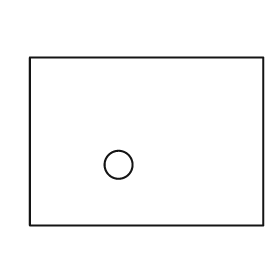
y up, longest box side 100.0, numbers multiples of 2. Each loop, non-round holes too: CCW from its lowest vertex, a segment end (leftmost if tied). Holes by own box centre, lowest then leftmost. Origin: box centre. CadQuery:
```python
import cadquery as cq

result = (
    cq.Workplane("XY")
    .moveTo(-50.0, -36.0)
    .lineTo(50.0, -36.0)
    .lineTo(50.0, 36.0)
    .lineTo(-50.0, 36.0)
    .close()
    .moveTo(-12.0, -10.0)
    .circle(6.0)
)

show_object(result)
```